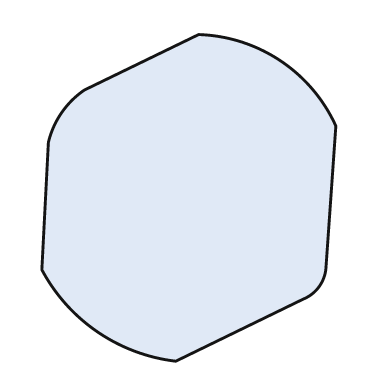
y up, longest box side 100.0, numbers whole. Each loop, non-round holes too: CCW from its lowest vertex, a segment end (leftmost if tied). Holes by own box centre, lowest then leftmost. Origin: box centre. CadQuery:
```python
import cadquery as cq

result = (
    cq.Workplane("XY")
    .moveTo(-4.0, -50.0)
    .lineTo(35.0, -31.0)
    .threePointArc((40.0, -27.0), (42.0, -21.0))
    .lineTo(45.0, 22.0)
    .threePointArc((28.0, 42.0), (3.0, 50.0))
    .lineTo(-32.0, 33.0)
    .threePointArc((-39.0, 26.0), (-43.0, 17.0))
    .lineTo(-45.0, -22.0)
    .threePointArc((-28.0, -41.0), (-4.0, -50.0))
    .close()
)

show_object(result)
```